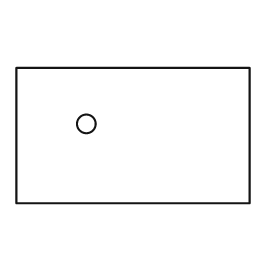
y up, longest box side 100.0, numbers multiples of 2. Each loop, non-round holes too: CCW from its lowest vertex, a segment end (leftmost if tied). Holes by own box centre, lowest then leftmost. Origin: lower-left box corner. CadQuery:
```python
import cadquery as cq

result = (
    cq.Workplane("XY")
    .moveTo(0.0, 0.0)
    .lineTo(100.0, 0.0)
    .lineTo(100.0, 58.0)
    .lineTo(0.0, 58.0)
    .close()
    .moveTo(30.0, 34.0)
    .circle(4.0)
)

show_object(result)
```